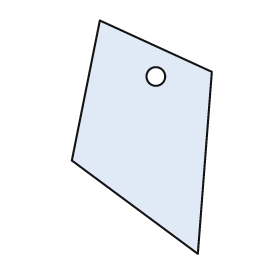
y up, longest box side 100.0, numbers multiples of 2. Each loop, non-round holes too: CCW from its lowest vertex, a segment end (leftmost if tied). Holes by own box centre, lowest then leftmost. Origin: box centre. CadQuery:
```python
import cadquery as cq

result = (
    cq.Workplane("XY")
    .moveTo(24.0, -50.0)
    .lineTo(30.0, 28.0)
    .lineTo(-18.0, 50.0)
    .lineTo(-30.0, -10.0)
    .close()
    .moveTo(6.0, 26.0)
    .circle(4.0)
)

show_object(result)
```